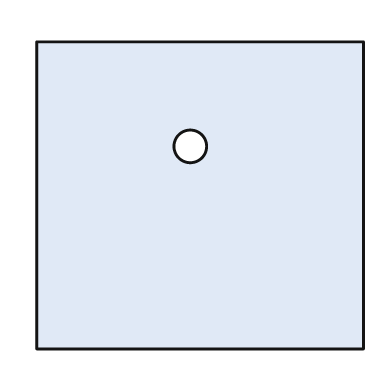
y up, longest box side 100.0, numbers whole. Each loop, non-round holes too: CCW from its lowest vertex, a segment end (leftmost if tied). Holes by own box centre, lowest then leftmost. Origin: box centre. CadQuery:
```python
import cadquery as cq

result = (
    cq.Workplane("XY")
    .moveTo(-50.0, -47.0)
    .lineTo(50.0, -47.0)
    .lineTo(50.0, 47.0)
    .lineTo(-50.0, 47.0)
    .close()
    .moveTo(-3.0, 15.0)
    .circle(5.0)
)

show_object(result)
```